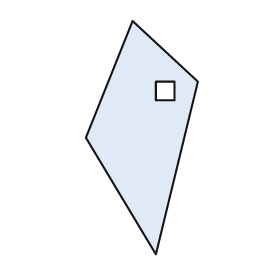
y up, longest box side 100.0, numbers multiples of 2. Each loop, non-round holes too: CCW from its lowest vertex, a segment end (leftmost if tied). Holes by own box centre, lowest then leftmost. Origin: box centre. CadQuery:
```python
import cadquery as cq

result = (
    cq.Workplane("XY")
    .moveTo(6.0, -50.0)
    .lineTo(24.0, 24.0)
    .lineTo(-4.0, 50.0)
    .lineTo(-24.0, 0.0)
    .close()
    .moveTo(6.0, 16.0)
    .lineTo(14.0, 16.0)
    .lineTo(14.0, 24.0)
    .lineTo(6.0, 24.0)
    .close()
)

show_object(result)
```